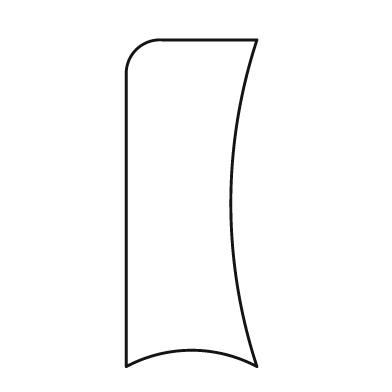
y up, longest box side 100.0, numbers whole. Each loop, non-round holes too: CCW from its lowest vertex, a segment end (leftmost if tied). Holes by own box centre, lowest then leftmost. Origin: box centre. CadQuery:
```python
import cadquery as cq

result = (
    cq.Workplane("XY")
    .moveTo(-20.0, -50.0)
    .threePointArc((0.0, -45.0), (20.0, -50.0))
    .threePointArc((12.0, 0.0), (20.0, 50.0))
    .lineTo(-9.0, 50.0)
    .threePointArc((-17.0, 47.0), (-20.0, 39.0))
    .close()
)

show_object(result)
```